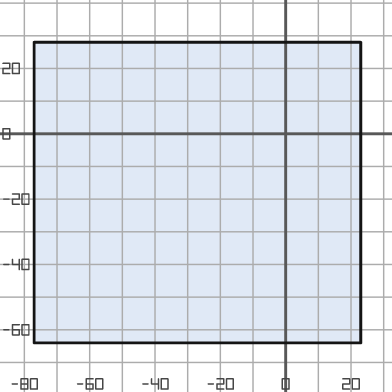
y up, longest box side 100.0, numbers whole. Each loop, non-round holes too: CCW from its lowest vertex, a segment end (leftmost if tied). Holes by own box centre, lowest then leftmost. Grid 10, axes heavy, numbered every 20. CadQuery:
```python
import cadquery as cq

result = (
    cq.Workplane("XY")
    .moveTo(-77.0, -64.0)
    .lineTo(23.0, -64.0)
    .lineTo(23.0, 28.0)
    .lineTo(-77.0, 28.0)
    .close()
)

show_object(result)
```